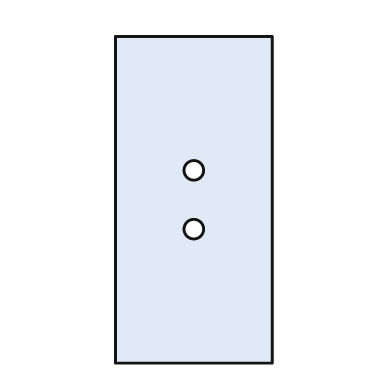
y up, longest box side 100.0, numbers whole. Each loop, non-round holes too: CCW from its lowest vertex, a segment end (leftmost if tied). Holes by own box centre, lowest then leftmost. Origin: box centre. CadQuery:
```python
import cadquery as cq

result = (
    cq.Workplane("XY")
    .moveTo(-24.0, -50.0)
    .lineTo(24.0, -50.0)
    .lineTo(24.0, 50.0)
    .lineTo(-24.0, 50.0)
    .close()
    .moveTo(0.0, -9.0)
    .circle(3.0)
    .moveTo(0.0, 9.0)
    .circle(3.0)
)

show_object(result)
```